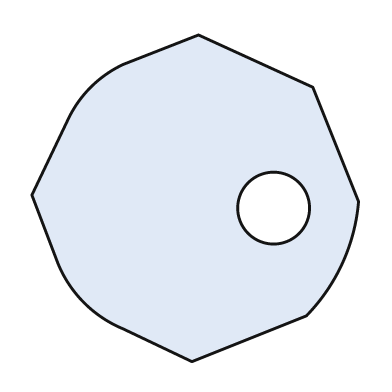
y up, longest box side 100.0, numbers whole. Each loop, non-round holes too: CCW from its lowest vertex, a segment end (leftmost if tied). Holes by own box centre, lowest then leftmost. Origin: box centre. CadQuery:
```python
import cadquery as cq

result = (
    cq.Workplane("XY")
    .moveTo(-1.0, -50.0)
    .lineTo(34.0, -36.0)
    .threePointArc((45.0, -20.0), (50.0, -1.0))
    .lineTo(36.0, 34.0)
    .lineTo(1.0, 50.0)
    .lineTo(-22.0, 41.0)
    .threePointArc((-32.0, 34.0), (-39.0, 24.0))
    .lineTo(-50.0, 1.0)
    .lineTo(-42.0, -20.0)
    .threePointArc((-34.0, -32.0), (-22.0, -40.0))
    .close()
    .moveTo(24.0, -3.0)
    .circle(11.0)
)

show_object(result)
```